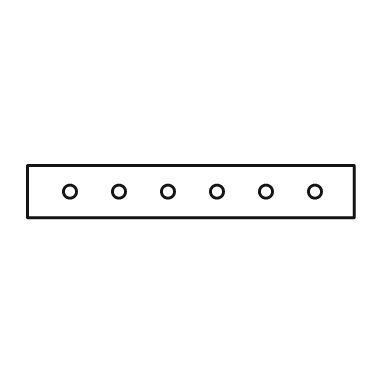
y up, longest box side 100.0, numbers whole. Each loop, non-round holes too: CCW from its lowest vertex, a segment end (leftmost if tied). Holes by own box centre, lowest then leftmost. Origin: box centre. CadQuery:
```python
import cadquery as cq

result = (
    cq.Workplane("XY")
    .moveTo(-50.0, -8.0)
    .lineTo(50.0, -8.0)
    .lineTo(50.0, 8.0)
    .lineTo(-50.0, 8.0)
    .close()
    .moveTo(-37.0, 0.0)
    .circle(2.0)
    .moveTo(-22.0, 0.0)
    .circle(2.0)
    .moveTo(-7.0, 0.0)
    .circle(2.0)
    .moveTo(8.0, 0.0)
    .circle(2.0)
    .moveTo(23.0, 0.0)
    .circle(2.0)
    .moveTo(38.0, 0.0)
    .circle(2.0)
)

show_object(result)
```